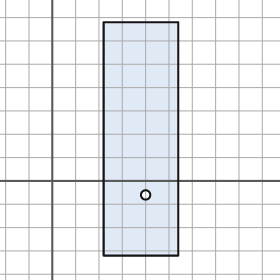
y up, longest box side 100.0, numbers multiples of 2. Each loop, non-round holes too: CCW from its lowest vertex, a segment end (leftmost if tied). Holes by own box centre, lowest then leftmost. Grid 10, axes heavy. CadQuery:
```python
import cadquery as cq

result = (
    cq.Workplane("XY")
    .moveTo(22.0, -32.0)
    .lineTo(54.0, -32.0)
    .lineTo(54.0, 68.0)
    .lineTo(22.0, 68.0)
    .close()
    .moveTo(40.0, -6.0)
    .circle(2.0)
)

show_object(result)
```